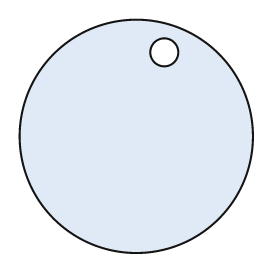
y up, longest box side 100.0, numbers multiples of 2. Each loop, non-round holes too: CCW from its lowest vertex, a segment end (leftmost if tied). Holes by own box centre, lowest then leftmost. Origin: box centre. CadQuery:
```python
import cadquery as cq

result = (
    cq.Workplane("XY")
    .moveTo(0.0, 0.0)
    .circle(50.0)
    .moveTo(12.0, 36.0)
    .circle(6.0)
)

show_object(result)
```